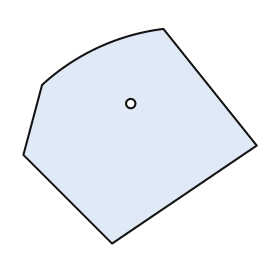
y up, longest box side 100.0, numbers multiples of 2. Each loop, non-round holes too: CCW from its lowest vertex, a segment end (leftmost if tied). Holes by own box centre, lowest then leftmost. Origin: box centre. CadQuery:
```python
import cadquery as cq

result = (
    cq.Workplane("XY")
    .moveTo(-12.0, -46.0)
    .lineTo(50.0, -4.0)
    .lineTo(10.0, 46.0)
    .threePointArc((-18.0, 38.0), (-42.0, 22.0))
    .lineTo(-50.0, -8.0)
    .close()
    .moveTo(-4.0, 14.0)
    .circle(2.0)
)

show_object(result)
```